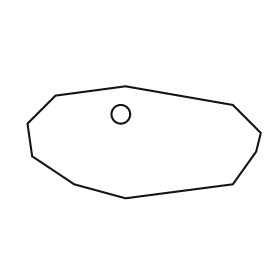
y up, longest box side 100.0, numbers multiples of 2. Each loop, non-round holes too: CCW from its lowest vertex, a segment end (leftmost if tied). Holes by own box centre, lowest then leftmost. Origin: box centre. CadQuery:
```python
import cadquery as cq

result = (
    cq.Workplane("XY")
    .moveTo(-8.0, -24.0)
    .lineTo(38.0, -18.0)
    .lineTo(48.0, -4.0)
    .lineTo(50.0, 4.0)
    .lineTo(38.0, 16.0)
    .lineTo(-8.0, 24.0)
    .lineTo(-38.0, 20.0)
    .lineTo(-50.0, 8.0)
    .lineTo(-48.0, -6.0)
    .lineTo(-30.0, -18.0)
    .close()
    .moveTo(-10.0, 12.0)
    .circle(4.0)
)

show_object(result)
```